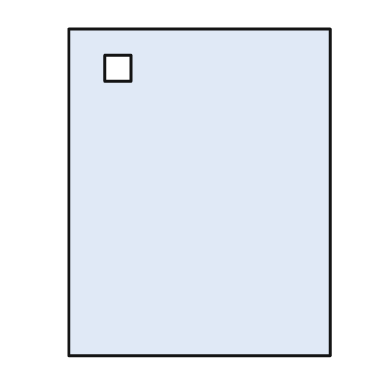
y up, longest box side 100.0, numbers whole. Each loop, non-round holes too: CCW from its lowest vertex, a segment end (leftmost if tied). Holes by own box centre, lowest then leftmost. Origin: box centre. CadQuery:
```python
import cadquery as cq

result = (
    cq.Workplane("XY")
    .moveTo(-40.0, -50.0)
    .lineTo(40.0, -50.0)
    .lineTo(40.0, 50.0)
    .lineTo(-40.0, 50.0)
    .close()
    .moveTo(-29.0, 34.0)
    .lineTo(-21.0, 34.0)
    .lineTo(-21.0, 42.0)
    .lineTo(-29.0, 42.0)
    .close()
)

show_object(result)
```